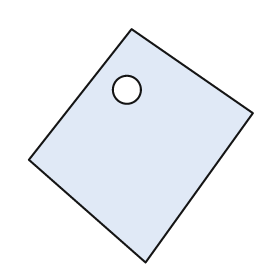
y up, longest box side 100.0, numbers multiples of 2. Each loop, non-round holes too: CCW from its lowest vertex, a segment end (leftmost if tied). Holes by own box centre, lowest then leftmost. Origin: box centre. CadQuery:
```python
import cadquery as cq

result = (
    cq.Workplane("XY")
    .moveTo(2.0, -50.0)
    .lineTo(48.0, 14.0)
    .lineTo(-4.0, 50.0)
    .lineTo(-48.0, -6.0)
    .close()
    .moveTo(-6.0, 24.0)
    .circle(6.0)
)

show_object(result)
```